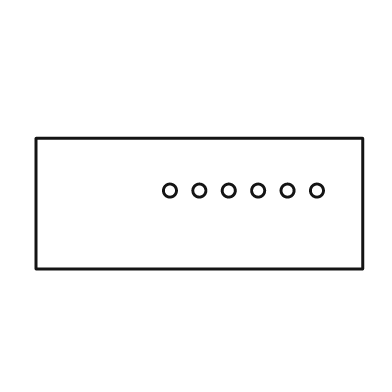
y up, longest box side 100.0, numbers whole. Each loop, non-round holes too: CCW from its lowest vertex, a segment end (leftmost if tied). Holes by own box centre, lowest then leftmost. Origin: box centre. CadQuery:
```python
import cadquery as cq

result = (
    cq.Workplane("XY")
    .moveTo(-50.0, -20.0)
    .lineTo(50.0, -20.0)
    .lineTo(50.0, 20.0)
    .lineTo(-50.0, 20.0)
    .close()
    .moveTo(-9.0, 4.0)
    .circle(2.0)
    .moveTo(0.0, 4.0)
    .circle(2.0)
    .moveTo(9.0, 4.0)
    .circle(2.0)
    .moveTo(18.0, 4.0)
    .circle(2.0)
    .moveTo(27.0, 4.0)
    .circle(2.0)
    .moveTo(36.0, 4.0)
    .circle(2.0)
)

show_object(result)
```